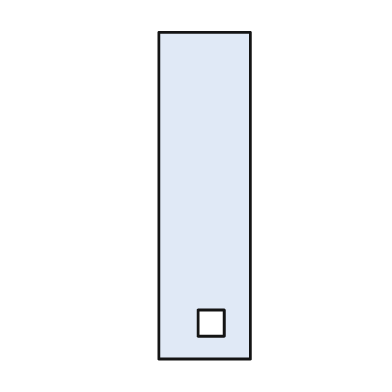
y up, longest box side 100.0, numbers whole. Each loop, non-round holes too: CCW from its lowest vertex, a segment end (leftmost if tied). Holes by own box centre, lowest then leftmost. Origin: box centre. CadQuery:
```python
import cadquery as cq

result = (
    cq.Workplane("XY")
    .moveTo(-14.0, -50.0)
    .lineTo(14.0, -50.0)
    .lineTo(14.0, 50.0)
    .lineTo(-14.0, 50.0)
    .close()
    .moveTo(-2.0, -43.0)
    .lineTo(6.0, -43.0)
    .lineTo(6.0, -35.0)
    .lineTo(-2.0, -35.0)
    .close()
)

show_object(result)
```